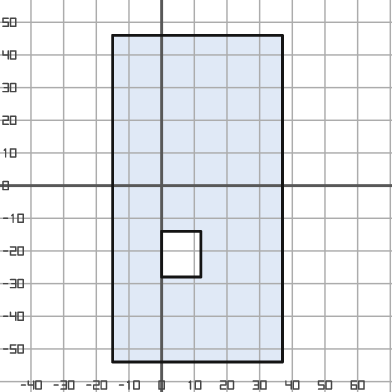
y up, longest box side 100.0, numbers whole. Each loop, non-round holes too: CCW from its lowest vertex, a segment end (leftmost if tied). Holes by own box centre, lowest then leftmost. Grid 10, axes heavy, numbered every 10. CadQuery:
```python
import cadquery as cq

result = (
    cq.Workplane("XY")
    .moveTo(-15.0, -54.0)
    .lineTo(37.0, -54.0)
    .lineTo(37.0, 46.0)
    .lineTo(-15.0, 46.0)
    .close()
    .moveTo(0.0, -28.0)
    .lineTo(12.0, -28.0)
    .lineTo(12.0, -14.0)
    .lineTo(0.0, -14.0)
    .close()
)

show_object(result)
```